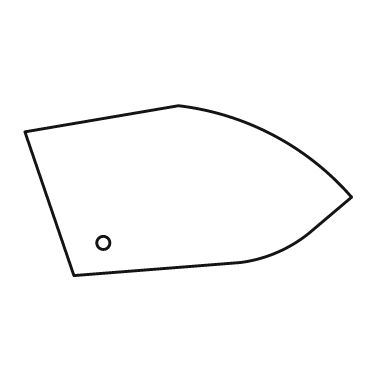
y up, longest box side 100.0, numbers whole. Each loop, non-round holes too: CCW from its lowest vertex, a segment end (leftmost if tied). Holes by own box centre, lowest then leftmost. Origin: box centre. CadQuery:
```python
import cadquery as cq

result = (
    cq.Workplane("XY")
    .moveTo(-35.0, -26.0)
    .lineTo(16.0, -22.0)
    .threePointArc((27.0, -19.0), (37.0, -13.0))
    .lineTo(50.0, -2.0)
    .threePointArc((26.0, 17.0), (-3.0, 26.0))
    .lineTo(-50.0, 18.0)
    .close()
    .moveTo(-26.0, -16.0)
    .circle(2.0)
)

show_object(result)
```